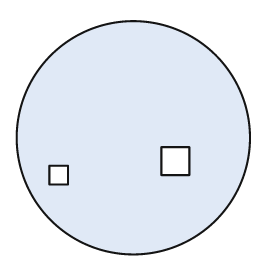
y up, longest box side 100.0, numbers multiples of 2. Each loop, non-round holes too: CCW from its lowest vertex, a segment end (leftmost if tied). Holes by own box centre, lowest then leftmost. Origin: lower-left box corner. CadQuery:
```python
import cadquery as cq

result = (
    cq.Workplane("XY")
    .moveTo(50.0, 50.0)
    .circle(50.0)
    .moveTo(14.0, 30.0)
    .lineTo(22.0, 30.0)
    .lineTo(22.0, 38.0)
    .lineTo(14.0, 38.0)
    .close()
    .moveTo(62.0, 34.0)
    .lineTo(74.0, 34.0)
    .lineTo(74.0, 46.0)
    .lineTo(62.0, 46.0)
    .close()
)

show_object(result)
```